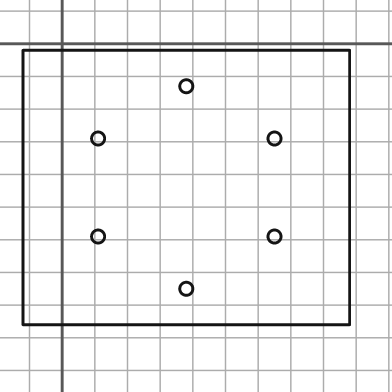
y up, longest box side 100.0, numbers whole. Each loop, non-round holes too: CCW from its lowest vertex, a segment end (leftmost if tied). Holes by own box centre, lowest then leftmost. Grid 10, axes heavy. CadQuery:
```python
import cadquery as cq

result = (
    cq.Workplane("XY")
    .moveTo(-12.0, -86.0)
    .lineTo(88.0, -86.0)
    .lineTo(88.0, -2.0)
    .lineTo(-12.0, -2.0)
    .close()
    .moveTo(38.0, -75.0)
    .circle(2.0)
    .moveTo(11.0, -59.0)
    .circle(2.0)
    .moveTo(65.0, -59.0)
    .circle(2.0)
    .moveTo(11.0, -29.0)
    .circle(2.0)
    .moveTo(65.0, -29.0)
    .circle(2.0)
    .moveTo(38.0, -13.0)
    .circle(2.0)
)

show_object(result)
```